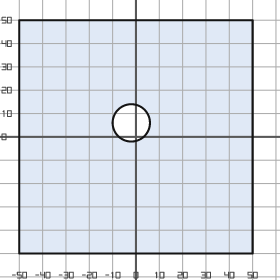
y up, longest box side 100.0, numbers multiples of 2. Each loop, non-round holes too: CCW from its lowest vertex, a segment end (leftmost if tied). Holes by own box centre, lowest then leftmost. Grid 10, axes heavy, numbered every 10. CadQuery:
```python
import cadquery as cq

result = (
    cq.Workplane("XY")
    .moveTo(-50.0, -50.0)
    .lineTo(50.0, -50.0)
    .lineTo(50.0, 50.0)
    .lineTo(-50.0, 50.0)
    .close()
    .moveTo(-2.0, 6.0)
    .circle(8.0)
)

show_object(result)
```